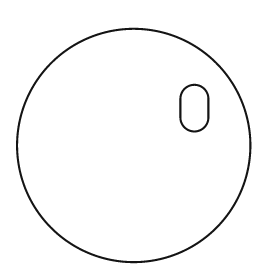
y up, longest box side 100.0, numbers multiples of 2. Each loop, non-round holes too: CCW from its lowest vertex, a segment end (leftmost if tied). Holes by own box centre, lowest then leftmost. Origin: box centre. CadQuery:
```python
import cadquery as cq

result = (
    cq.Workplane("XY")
    .moveTo(0.0, 0.0)
    .circle(50.0)
    .moveTo(20.0, 12.0)
    .threePointArc((26.0, 6.0), (32.0, 12.0))
    .lineTo(32.0, 20.0)
    .threePointArc((26.0, 26.0), (20.0, 20.0))
    .close()
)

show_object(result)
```